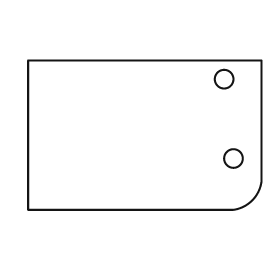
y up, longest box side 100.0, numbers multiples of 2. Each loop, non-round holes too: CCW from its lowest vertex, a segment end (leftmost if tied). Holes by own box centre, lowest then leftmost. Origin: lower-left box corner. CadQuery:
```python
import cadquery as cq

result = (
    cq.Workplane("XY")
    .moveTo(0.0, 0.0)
    .lineTo(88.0, 0.0)
    .threePointArc((96.0, 4.0), (100.0, 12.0))
    .lineTo(100.0, 64.0)
    .lineTo(0.0, 64.0)
    .close()
    .moveTo(88.0, 22.0)
    .circle(4.0)
    .moveTo(84.0, 56.0)
    .circle(4.0)
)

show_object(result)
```